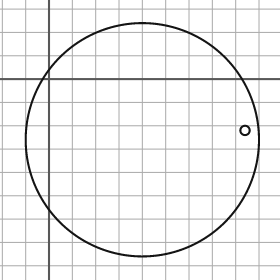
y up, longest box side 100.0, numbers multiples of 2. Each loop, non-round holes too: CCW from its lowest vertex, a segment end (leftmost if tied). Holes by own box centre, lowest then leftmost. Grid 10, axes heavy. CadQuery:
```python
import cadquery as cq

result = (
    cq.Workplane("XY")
    .moveTo(40.0, -26.0)
    .circle(50.0)
    .moveTo(84.0, -22.0)
    .circle(2.0)
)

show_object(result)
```